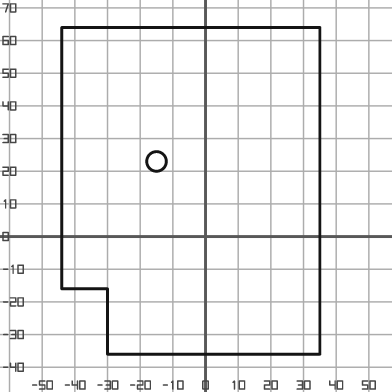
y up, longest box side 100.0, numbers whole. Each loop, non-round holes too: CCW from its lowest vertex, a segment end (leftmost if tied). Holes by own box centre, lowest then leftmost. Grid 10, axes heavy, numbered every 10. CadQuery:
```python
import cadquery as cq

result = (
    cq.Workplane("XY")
    .moveTo(-30.0, -36.0)
    .lineTo(35.0, -36.0)
    .lineTo(35.0, 64.0)
    .lineTo(-44.0, 64.0)
    .lineTo(-44.0, -16.0)
    .lineTo(-30.0, -16.0)
    .close()
    .moveTo(-15.0, 23.0)
    .circle(3.0)
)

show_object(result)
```